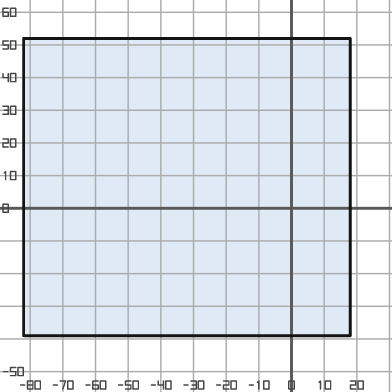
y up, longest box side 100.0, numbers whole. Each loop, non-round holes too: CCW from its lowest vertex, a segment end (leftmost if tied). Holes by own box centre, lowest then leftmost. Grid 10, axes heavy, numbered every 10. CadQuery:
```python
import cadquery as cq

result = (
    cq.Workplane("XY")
    .moveTo(-82.0, -39.0)
    .lineTo(18.0, -39.0)
    .lineTo(18.0, 52.0)
    .lineTo(-82.0, 52.0)
    .close()
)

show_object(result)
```